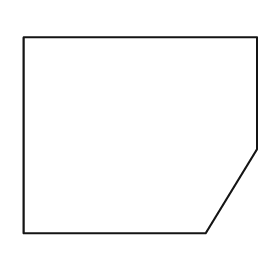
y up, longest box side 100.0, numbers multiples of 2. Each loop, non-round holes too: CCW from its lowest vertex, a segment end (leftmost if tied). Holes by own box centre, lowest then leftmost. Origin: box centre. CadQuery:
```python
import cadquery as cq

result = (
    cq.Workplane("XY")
    .moveTo(-50.0, -42.0)
    .lineTo(28.0, -42.0)
    .lineTo(50.0, -6.0)
    .lineTo(50.0, 42.0)
    .lineTo(-50.0, 42.0)
    .close()
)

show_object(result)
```